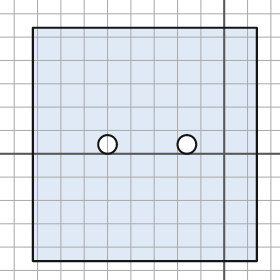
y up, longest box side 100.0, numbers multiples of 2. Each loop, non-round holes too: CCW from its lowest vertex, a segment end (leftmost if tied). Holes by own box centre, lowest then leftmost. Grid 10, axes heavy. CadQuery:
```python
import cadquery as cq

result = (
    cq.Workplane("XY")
    .moveTo(-82.0, -46.0)
    .lineTo(14.0, -46.0)
    .lineTo(14.0, 54.0)
    .lineTo(-82.0, 54.0)
    .close()
    .moveTo(-50.0, 4.0)
    .circle(4.0)
    .moveTo(-16.0, 4.0)
    .circle(4.0)
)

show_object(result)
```